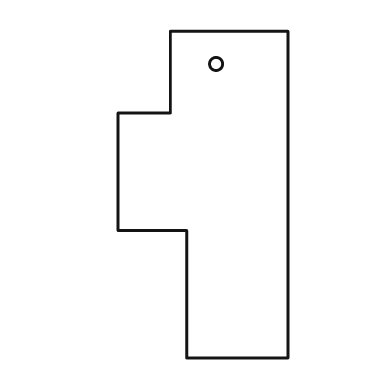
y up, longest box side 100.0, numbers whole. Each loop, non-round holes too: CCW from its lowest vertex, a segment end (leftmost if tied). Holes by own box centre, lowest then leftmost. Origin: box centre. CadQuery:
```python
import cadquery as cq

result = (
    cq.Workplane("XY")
    .moveTo(-5.0, -50.0)
    .lineTo(26.0, -50.0)
    .lineTo(26.0, 50.0)
    .lineTo(-10.0, 50.0)
    .lineTo(-10.0, 25.0)
    .lineTo(-26.0, 25.0)
    .lineTo(-26.0, -11.0)
    .lineTo(-5.0, -11.0)
    .close()
    .moveTo(4.0, 40.0)
    .circle(2.0)
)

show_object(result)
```